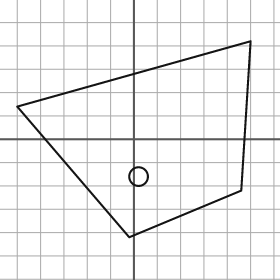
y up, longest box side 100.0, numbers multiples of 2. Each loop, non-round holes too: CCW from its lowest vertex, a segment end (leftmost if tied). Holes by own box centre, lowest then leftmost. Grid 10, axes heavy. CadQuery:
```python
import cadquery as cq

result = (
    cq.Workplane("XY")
    .moveTo(-2.0, -42.0)
    .lineTo(46.0, -22.0)
    .lineTo(50.0, 42.0)
    .lineTo(-50.0, 14.0)
    .close()
    .moveTo(2.0, -16.0)
    .circle(4.0)
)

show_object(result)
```